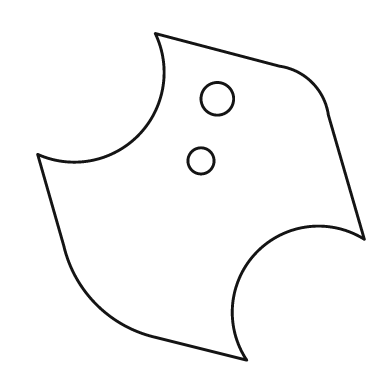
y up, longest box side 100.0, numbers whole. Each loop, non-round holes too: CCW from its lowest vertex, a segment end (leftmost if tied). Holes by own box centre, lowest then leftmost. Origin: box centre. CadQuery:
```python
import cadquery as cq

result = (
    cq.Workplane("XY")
    .moveTo(14.0, -50.0)
    .threePointArc((17.0, -17.0), (50.0, -13.0))
    .lineTo(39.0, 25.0)
    .threePointArc((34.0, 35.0), (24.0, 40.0))
    .lineTo(-14.0, 50.0)
    .threePointArc((-19.0, 19.0), (-50.0, 13.0))
    .lineTo(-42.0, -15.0)
    .threePointArc((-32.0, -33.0), (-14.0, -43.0))
    .close()
    .moveTo(0.0, 11.0)
    .circle(4.0)
    .moveTo(5.0, 30.0)
    .circle(5.0)
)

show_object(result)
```